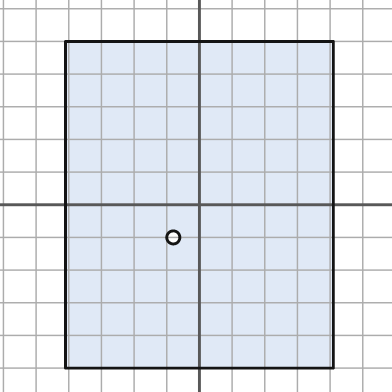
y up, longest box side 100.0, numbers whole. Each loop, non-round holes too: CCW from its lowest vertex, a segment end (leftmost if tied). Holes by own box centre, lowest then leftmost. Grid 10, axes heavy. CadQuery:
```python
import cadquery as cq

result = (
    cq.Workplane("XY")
    .moveTo(-41.0, -50.0)
    .lineTo(41.0, -50.0)
    .lineTo(41.0, 50.0)
    .lineTo(-41.0, 50.0)
    .close()
    .moveTo(-8.0, -10.0)
    .circle(2.0)
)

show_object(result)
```